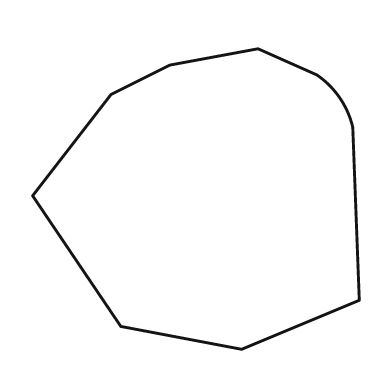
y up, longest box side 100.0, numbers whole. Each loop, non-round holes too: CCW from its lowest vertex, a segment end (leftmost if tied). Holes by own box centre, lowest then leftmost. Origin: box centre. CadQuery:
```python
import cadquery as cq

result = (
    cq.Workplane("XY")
    .moveTo(14.0, -46.0)
    .lineTo(50.0, -31.0)
    .lineTo(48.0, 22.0)
    .threePointArc((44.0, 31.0), (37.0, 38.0))
    .lineTo(19.0, 46.0)
    .lineTo(-8.0, 41.0)
    .lineTo(-26.0, 32.0)
    .lineTo(-50.0, 1.0)
    .lineTo(-23.0, -39.0)
    .close()
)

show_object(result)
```